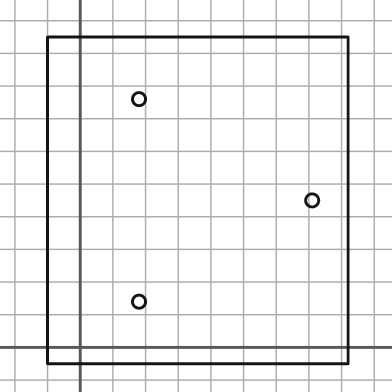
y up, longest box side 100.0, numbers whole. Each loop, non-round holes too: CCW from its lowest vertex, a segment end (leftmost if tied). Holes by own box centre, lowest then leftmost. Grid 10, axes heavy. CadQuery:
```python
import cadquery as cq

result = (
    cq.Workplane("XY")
    .moveTo(-10.0, -5.0)
    .lineTo(82.0, -5.0)
    .lineTo(82.0, 95.0)
    .lineTo(-10.0, 95.0)
    .close()
    .moveTo(18.0, 14.0)
    .circle(2.0)
    .moveTo(71.0, 45.0)
    .circle(2.0)
    .moveTo(18.0, 76.0)
    .circle(2.0)
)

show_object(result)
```